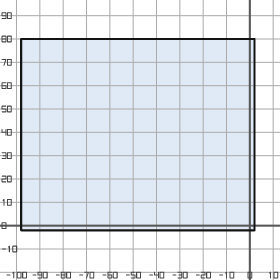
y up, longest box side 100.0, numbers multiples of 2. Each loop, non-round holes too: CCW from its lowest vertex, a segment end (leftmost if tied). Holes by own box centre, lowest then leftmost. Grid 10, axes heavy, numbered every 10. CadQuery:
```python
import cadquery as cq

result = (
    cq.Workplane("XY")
    .moveTo(-98.0, -2.0)
    .lineTo(2.0, -2.0)
    .lineTo(2.0, 80.0)
    .lineTo(-98.0, 80.0)
    .close()
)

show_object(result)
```